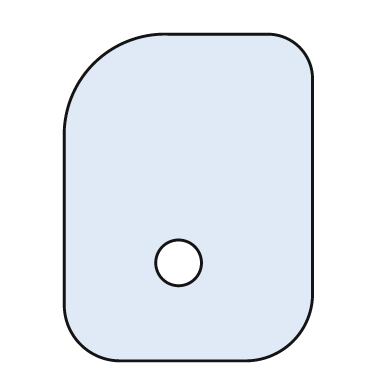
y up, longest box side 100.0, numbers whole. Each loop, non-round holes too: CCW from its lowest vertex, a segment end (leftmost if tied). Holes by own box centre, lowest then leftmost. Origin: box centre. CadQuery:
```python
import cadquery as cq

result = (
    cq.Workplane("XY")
    .moveTo(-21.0, -50.0)
    .lineTo(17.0, -50.0)
    .threePointArc((32.0, -44.0), (38.0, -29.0))
    .lineTo(38.0, 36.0)
    .threePointArc((34.0, 46.0), (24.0, 50.0))
    .lineTo(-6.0, 50.0)
    .threePointArc((-29.0, 41.0), (-38.0, 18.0))
    .lineTo(-38.0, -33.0)
    .threePointArc((-33.0, -45.0), (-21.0, -50.0))
    .close()
    .moveTo(-3.0, -20.0)
    .circle(7.0)
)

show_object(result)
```